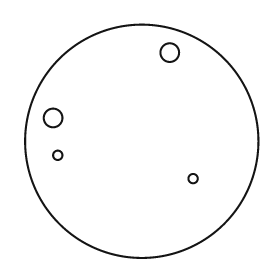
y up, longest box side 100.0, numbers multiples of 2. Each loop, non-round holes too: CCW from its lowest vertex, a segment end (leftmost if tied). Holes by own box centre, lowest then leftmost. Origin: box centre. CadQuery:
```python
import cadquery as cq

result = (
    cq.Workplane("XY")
    .moveTo(0.0, 0.0)
    .circle(50.0)
    .moveTo(22.0, -16.0)
    .circle(2.0)
    .moveTo(-36.0, -6.0)
    .circle(2.0)
    .moveTo(-38.0, 10.0)
    .circle(4.0)
    .moveTo(12.0, 38.0)
    .circle(4.0)
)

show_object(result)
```